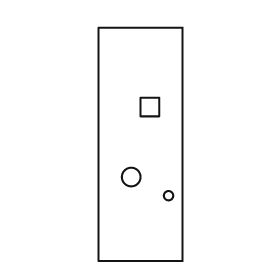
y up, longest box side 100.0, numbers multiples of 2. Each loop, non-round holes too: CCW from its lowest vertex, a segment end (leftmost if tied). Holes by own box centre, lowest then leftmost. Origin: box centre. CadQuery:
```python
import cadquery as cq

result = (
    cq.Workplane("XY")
    .moveTo(-18.0, -50.0)
    .lineTo(18.0, -50.0)
    .lineTo(18.0, 50.0)
    .lineTo(-18.0, 50.0)
    .close()
    .moveTo(12.0, -22.0)
    .circle(2.0)
    .moveTo(-4.0, -14.0)
    .circle(4.0)
    .moveTo(0.0, 12.0)
    .lineTo(8.0, 12.0)
    .lineTo(8.0, 20.0)
    .lineTo(0.0, 20.0)
    .close()
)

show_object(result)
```